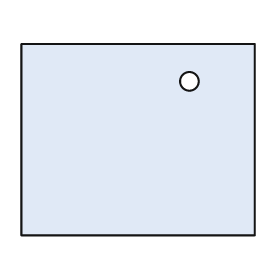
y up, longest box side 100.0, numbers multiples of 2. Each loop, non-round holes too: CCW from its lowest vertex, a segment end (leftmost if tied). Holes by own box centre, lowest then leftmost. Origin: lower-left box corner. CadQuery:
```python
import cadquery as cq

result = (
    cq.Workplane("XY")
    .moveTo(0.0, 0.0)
    .lineTo(100.0, 0.0)
    .lineTo(100.0, 82.0)
    .lineTo(0.0, 82.0)
    .close()
    .moveTo(72.0, 66.0)
    .circle(4.0)
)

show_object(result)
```